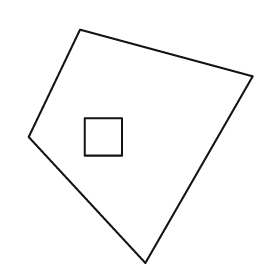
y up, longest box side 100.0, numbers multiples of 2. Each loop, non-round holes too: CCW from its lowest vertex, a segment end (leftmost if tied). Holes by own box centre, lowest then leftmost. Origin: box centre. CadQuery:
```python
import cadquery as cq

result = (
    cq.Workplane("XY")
    .moveTo(2.0, -50.0)
    .lineTo(48.0, 30.0)
    .lineTo(-26.0, 50.0)
    .lineTo(-48.0, 4.0)
    .close()
    .moveTo(-24.0, -4.0)
    .lineTo(-8.0, -4.0)
    .lineTo(-8.0, 12.0)
    .lineTo(-24.0, 12.0)
    .close()
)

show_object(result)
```